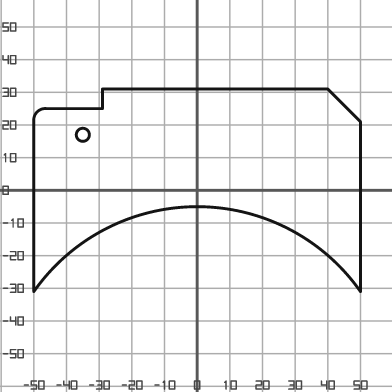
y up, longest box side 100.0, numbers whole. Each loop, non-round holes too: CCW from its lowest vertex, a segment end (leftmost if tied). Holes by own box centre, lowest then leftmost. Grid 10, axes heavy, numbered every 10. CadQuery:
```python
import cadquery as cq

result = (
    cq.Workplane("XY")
    .moveTo(-50.0, -31.0)
    .threePointArc((0.0, -5.0), (50.0, -31.0))
    .lineTo(50.0, 21.0)
    .lineTo(40.0, 31.0)
    .lineTo(-29.0, 31.0)
    .lineTo(-29.0, 25.0)
    .lineTo(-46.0, 25.0)
    .threePointArc((-49.0, 24.0), (-50.0, 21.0))
    .close()
    .moveTo(-35.0, 17.0)
    .circle(2.0)
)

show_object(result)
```